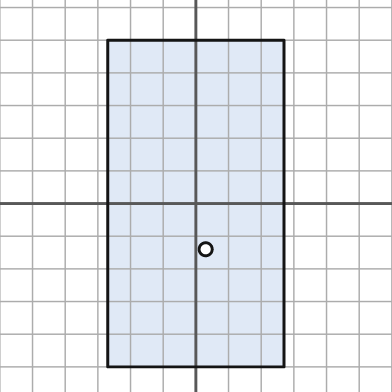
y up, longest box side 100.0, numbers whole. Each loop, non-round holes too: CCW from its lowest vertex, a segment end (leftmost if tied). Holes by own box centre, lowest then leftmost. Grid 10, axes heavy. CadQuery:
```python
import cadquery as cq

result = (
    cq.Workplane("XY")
    .moveTo(-27.0, -50.0)
    .lineTo(27.0, -50.0)
    .lineTo(27.0, 50.0)
    .lineTo(-27.0, 50.0)
    .close()
    .moveTo(3.0, -14.0)
    .circle(2.0)
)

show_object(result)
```